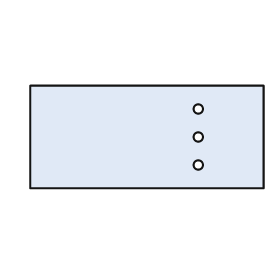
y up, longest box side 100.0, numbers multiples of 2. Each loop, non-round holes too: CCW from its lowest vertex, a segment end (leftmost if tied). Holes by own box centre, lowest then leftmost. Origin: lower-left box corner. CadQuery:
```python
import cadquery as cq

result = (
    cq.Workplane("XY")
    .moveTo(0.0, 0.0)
    .lineTo(100.0, 0.0)
    .lineTo(100.0, 44.0)
    .lineTo(0.0, 44.0)
    .close()
    .moveTo(72.0, 10.0)
    .circle(2.0)
    .moveTo(72.0, 22.0)
    .circle(2.0)
    .moveTo(72.0, 34.0)
    .circle(2.0)
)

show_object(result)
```